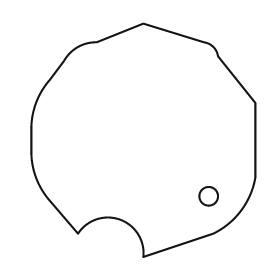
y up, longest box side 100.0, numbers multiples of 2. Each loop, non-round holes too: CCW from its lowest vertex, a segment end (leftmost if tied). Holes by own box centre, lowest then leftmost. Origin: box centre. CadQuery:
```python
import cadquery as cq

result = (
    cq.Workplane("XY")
    .moveTo(0.0, -50.0)
    .lineTo(30.0, -40.0)
    .threePointArc((42.0, -30.0), (48.0, -16.0))
    .lineTo(48.0, 16.0)
    .lineTo(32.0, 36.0)
    .threePointArc((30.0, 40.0), (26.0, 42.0))
    .lineTo(0.0, 50.0)
    .lineTo(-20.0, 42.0)
    .threePointArc((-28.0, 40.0), (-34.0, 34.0))
    .lineTo(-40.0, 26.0)
    .threePointArc((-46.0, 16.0), (-48.0, 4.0))
    .lineTo(-48.0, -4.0)
    .threePointArc((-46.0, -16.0), (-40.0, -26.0))
    .lineTo(-28.0, -40.0)
    .threePointArc((-10.0, -34.0), (0.0, -50.0))
    .close()
    .moveTo(28.0, -24.0)
    .circle(4.0)
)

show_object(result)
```